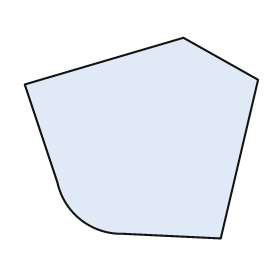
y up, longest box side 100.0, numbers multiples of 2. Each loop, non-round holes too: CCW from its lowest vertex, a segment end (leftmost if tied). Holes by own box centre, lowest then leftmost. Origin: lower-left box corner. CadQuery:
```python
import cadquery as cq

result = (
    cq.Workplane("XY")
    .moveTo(84.0, 0.0)
    .lineTo(100.0, 68.0)
    .lineTo(68.0, 86.0)
    .lineTo(0.0, 66.0)
    .lineTo(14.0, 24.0)
    .threePointArc((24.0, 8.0), (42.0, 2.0))
    .close()
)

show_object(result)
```